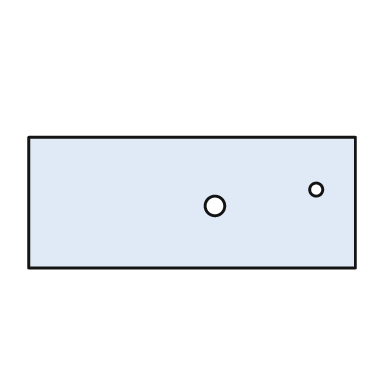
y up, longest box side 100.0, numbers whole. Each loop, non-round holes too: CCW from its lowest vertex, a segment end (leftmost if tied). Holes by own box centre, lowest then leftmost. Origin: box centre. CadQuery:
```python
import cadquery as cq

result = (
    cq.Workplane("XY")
    .moveTo(-50.0, -20.0)
    .lineTo(50.0, -20.0)
    .lineTo(50.0, 20.0)
    .lineTo(-50.0, 20.0)
    .close()
    .moveTo(7.0, -1.0)
    .circle(3.0)
    .moveTo(38.0, 4.0)
    .circle(2.0)
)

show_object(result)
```